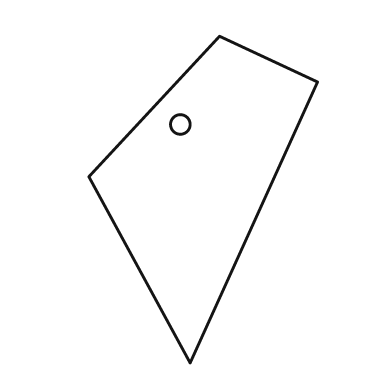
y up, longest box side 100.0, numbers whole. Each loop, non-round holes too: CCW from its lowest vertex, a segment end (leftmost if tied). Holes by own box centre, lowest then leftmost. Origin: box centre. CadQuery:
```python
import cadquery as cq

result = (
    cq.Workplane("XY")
    .moveTo(-4.0, -50.0)
    .lineTo(35.0, 36.0)
    .lineTo(5.0, 50.0)
    .lineTo(-35.0, 7.0)
    .close()
    .moveTo(-7.0, 23.0)
    .circle(3.0)
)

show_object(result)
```